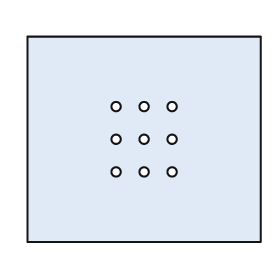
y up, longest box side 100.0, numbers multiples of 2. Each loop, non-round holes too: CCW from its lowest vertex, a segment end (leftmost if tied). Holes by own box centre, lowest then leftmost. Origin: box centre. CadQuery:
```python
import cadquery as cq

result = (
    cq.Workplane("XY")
    .moveTo(-50.0, -44.0)
    .lineTo(50.0, -44.0)
    .lineTo(50.0, 44.0)
    .lineTo(-50.0, 44.0)
    .close()
    .moveTo(-12.0, -14.0)
    .circle(2.0)
    .moveTo(0.0, -14.0)
    .circle(2.0)
    .moveTo(12.0, -14.0)
    .circle(2.0)
    .moveTo(-12.0, 0.0)
    .circle(2.0)
    .moveTo(0.0, 0.0)
    .circle(2.0)
    .moveTo(12.0, 0.0)
    .circle(2.0)
    .moveTo(-12.0, 14.0)
    .circle(2.0)
    .moveTo(0.0, 14.0)
    .circle(2.0)
    .moveTo(12.0, 14.0)
    .circle(2.0)
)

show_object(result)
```